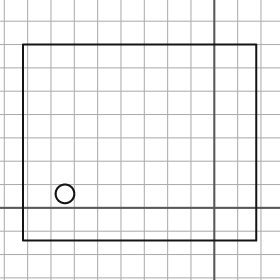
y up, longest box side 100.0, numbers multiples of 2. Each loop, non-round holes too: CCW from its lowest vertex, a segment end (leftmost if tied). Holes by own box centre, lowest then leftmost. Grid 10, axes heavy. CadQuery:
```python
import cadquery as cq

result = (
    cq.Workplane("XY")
    .moveTo(-82.0, -14.0)
    .lineTo(18.0, -14.0)
    .lineTo(18.0, 70.0)
    .lineTo(-82.0, 70.0)
    .close()
    .moveTo(-64.0, 6.0)
    .circle(4.0)
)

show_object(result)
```